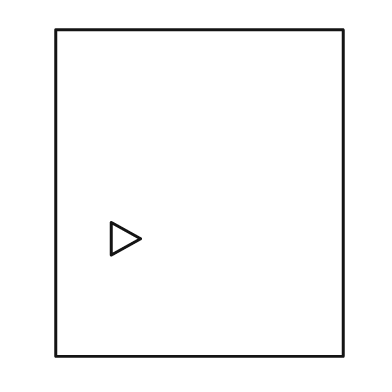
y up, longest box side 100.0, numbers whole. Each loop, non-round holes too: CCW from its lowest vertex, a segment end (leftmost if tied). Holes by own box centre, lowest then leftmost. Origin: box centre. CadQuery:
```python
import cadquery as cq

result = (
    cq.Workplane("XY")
    .moveTo(-44.0, -50.0)
    .lineTo(44.0, -50.0)
    .lineTo(44.0, 50.0)
    .lineTo(-44.0, 50.0)
    .close()
    .moveTo(-27.0, -19.0)
    .lineTo(-18.0, -14.0)
    .lineTo(-27.0, -9.0)
    .close()
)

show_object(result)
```